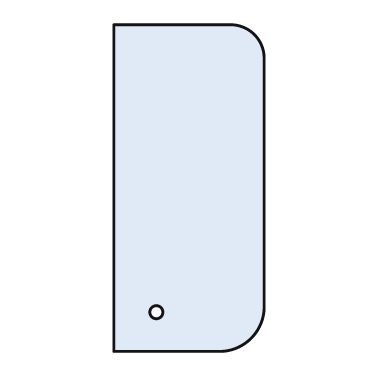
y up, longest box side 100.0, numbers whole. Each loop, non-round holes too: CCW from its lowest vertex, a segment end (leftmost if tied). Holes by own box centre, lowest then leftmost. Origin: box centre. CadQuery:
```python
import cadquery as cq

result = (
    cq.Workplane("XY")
    .moveTo(-23.0, -50.0)
    .lineTo(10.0, -50.0)
    .threePointArc((19.0, -46.0), (23.0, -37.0))
    .lineTo(23.0, 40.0)
    .threePointArc((20.0, 47.0), (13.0, 50.0))
    .lineTo(-23.0, 50.0)
    .close()
    .moveTo(-10.0, -38.0)
    .circle(2.0)
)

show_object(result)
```